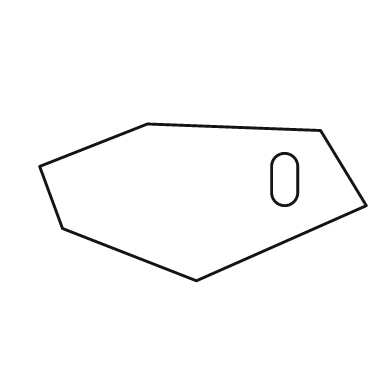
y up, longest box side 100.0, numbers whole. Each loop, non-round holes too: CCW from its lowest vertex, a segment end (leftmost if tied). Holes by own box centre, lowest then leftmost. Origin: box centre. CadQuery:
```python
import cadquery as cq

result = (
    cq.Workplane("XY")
    .moveTo(-2.0, -24.0)
    .lineTo(50.0, -1.0)
    .lineTo(36.0, 22.0)
    .lineTo(-17.0, 24.0)
    .lineTo(-50.0, 11.0)
    .lineTo(-43.0, -8.0)
    .close()
    .moveTo(21.0, 3.0)
    .threePointArc((25.0, -1.0), (29.0, 3.0))
    .lineTo(29.0, 11.0)
    .threePointArc((25.0, 15.0), (21.0, 11.0))
    .close()
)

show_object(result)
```